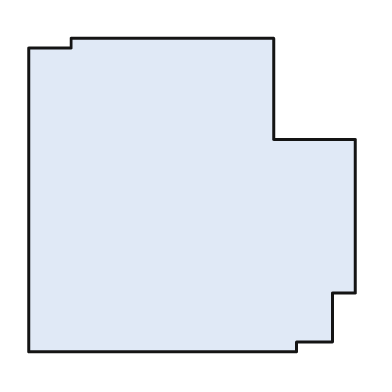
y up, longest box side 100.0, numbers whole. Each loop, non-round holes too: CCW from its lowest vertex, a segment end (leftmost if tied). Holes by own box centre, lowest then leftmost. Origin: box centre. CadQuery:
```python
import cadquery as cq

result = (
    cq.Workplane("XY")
    .moveTo(-50.0, -48.0)
    .lineTo(32.0, -48.0)
    .lineTo(32.0, -45.0)
    .lineTo(43.0, -45.0)
    .lineTo(43.0, -30.0)
    .lineTo(50.0, -30.0)
    .lineTo(50.0, 17.0)
    .lineTo(25.0, 17.0)
    .lineTo(25.0, 48.0)
    .lineTo(-37.0, 48.0)
    .lineTo(-37.0, 45.0)
    .lineTo(-50.0, 45.0)
    .close()
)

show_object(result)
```